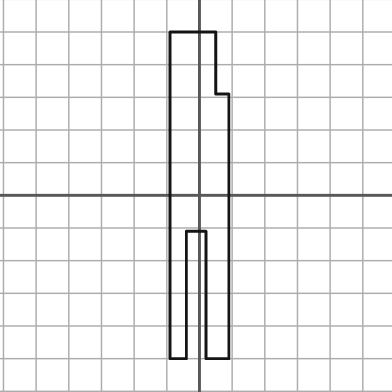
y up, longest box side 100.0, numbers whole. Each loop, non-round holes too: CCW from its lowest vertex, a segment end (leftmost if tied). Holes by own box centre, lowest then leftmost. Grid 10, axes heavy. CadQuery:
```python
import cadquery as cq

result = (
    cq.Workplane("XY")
    .moveTo(-9.0, -50.0)
    .lineTo(-4.0, -50.0)
    .lineTo(-4.0, -11.0)
    .lineTo(2.0, -11.0)
    .lineTo(2.0, -50.0)
    .lineTo(9.0, -50.0)
    .lineTo(9.0, 31.0)
    .lineTo(5.0, 31.0)
    .lineTo(5.0, 50.0)
    .lineTo(-9.0, 50.0)
    .close()
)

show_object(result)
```